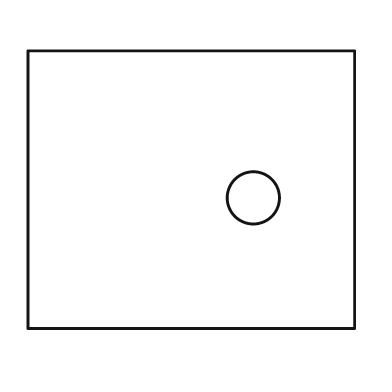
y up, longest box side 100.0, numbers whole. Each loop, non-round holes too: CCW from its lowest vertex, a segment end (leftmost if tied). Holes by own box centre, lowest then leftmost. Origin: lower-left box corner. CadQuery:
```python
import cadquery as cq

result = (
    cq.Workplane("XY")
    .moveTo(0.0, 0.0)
    .lineTo(100.0, 0.0)
    .lineTo(100.0, 85.0)
    .lineTo(0.0, 85.0)
    .close()
    .moveTo(69.0, 40.0)
    .circle(8.0)
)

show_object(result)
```